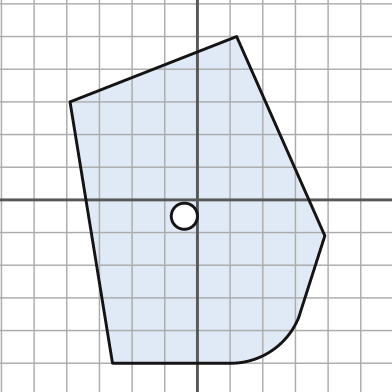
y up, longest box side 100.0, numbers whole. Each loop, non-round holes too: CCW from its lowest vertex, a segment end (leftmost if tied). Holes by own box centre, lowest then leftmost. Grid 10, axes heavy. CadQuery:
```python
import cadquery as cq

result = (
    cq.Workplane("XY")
    .moveTo(-26.0, -50.0)
    .lineTo(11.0, -50.0)
    .threePointArc((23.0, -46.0), (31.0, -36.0))
    .lineTo(39.0, -11.0)
    .lineTo(12.0, 50.0)
    .lineTo(-39.0, 30.0)
    .close()
    .moveTo(-4.0, -5.0)
    .circle(4.0)
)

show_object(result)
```